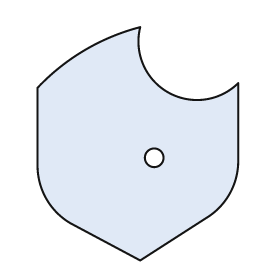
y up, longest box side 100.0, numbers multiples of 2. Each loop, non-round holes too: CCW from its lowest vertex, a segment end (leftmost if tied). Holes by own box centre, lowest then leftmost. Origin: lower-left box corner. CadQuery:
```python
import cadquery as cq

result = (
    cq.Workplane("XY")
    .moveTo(44.0, 0.0)
    .lineTo(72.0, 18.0)
    .threePointArc((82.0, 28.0), (86.0, 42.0))
    .lineTo(86.0, 76.0)
    .threePointArc((56.0, 72.0), (44.0, 100.0))
    .threePointArc((20.0, 90.0), (0.0, 74.0))
    .lineTo(0.0, 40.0)
    .threePointArc((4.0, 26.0), (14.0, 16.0))
    .close()
    .moveTo(50.0, 44.0)
    .circle(4.0)
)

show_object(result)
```